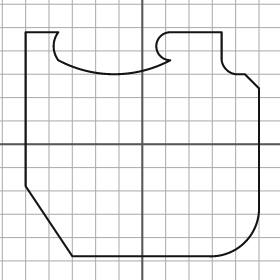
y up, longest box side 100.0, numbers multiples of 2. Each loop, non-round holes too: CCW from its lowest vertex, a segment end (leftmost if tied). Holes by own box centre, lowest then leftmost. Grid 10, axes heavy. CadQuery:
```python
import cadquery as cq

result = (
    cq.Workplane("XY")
    .moveTo(-30.0, -48.0)
    .lineTo(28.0, -48.0)
    .threePointArc((44.0, -42.0), (50.0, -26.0))
    .lineTo(50.0, 24.0)
    .lineTo(44.0, 30.0)
    .lineTo(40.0, 30.0)
    .threePointArc((36.0, 32.0), (34.0, 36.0))
    .lineTo(34.0, 48.0)
    .lineTo(12.0, 48.0)
    .threePointArc((6.0, 42.0), (12.0, 36.0))
    .threePointArc((-12.0, 30.0), (-36.0, 36.0))
    .threePointArc((-38.0, 42.0), (-36.0, 48.0))
    .lineTo(-50.0, 48.0)
    .lineTo(-50.0, -18.0)
    .close()
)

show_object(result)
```